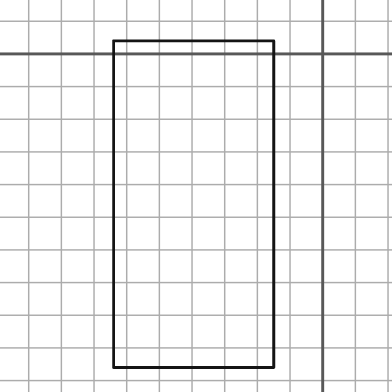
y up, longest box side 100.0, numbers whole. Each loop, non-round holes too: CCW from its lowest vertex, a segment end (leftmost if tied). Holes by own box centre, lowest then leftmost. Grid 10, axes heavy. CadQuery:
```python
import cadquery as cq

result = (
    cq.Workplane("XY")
    .moveTo(-64.0, -96.0)
    .lineTo(-15.0, -96.0)
    .lineTo(-15.0, 4.0)
    .lineTo(-64.0, 4.0)
    .close()
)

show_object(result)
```